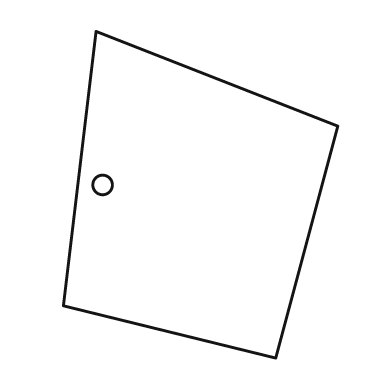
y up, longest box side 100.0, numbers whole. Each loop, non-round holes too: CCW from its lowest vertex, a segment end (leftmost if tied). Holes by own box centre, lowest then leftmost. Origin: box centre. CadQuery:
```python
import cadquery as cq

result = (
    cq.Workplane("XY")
    .moveTo(23.0, -50.0)
    .lineTo(42.0, 21.0)
    .lineTo(-32.0, 50.0)
    .lineTo(-42.0, -34.0)
    .close()
    .moveTo(-30.0, 3.0)
    .circle(3.0)
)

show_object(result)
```